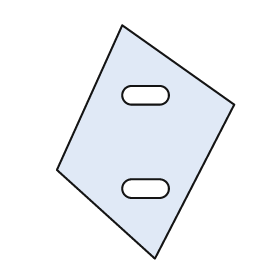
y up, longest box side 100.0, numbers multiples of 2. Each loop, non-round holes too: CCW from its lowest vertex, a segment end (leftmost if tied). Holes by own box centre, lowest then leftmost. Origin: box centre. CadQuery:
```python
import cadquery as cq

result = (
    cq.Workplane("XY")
    .moveTo(4.0, -50.0)
    .lineTo(38.0, 16.0)
    .lineTo(-10.0, 50.0)
    .lineTo(-38.0, -12.0)
    .close()
    .moveTo(-6.0, -24.0)
    .lineTo(6.0, -24.0)
    .threePointArc((10.0, -20.0), (6.0, -16.0))
    .lineTo(-6.0, -16.0)
    .threePointArc((-10.0, -20.0), (-6.0, -24.0))
    .close()
    .moveTo(-6.0, 16.0)
    .lineTo(6.0, 16.0)
    .threePointArc((10.0, 20.0), (6.0, 24.0))
    .lineTo(-6.0, 24.0)
    .threePointArc((-10.0, 20.0), (-6.0, 16.0))
    .close()
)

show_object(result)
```